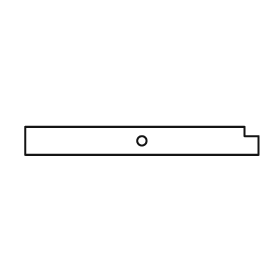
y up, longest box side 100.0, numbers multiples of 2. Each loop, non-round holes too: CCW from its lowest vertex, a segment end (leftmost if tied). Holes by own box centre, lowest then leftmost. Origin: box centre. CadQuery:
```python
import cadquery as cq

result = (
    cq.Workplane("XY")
    .moveTo(-50.0, -6.0)
    .lineTo(50.0, -6.0)
    .lineTo(50.0, 2.0)
    .lineTo(44.0, 2.0)
    .lineTo(44.0, 6.0)
    .lineTo(-50.0, 6.0)
    .close()
    .moveTo(0.0, 0.0)
    .circle(2.0)
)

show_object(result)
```